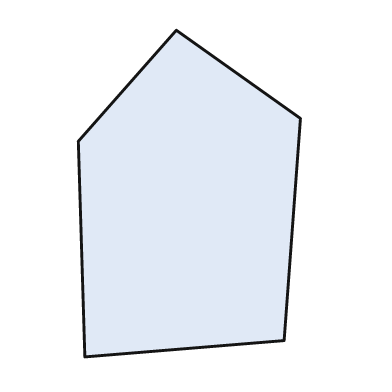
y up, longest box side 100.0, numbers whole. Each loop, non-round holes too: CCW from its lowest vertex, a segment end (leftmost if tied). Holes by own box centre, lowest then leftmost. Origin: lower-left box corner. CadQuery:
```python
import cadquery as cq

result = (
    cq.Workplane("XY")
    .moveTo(2.0, 0.0)
    .lineTo(63.0, 5.0)
    .lineTo(68.0, 73.0)
    .lineTo(30.0, 100.0)
    .lineTo(0.0, 66.0)
    .close()
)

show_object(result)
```